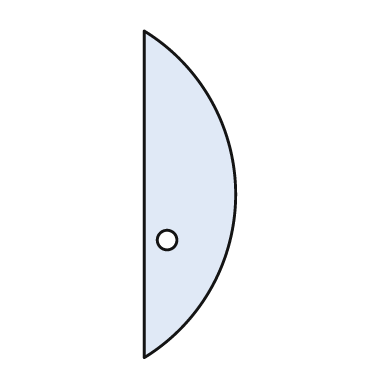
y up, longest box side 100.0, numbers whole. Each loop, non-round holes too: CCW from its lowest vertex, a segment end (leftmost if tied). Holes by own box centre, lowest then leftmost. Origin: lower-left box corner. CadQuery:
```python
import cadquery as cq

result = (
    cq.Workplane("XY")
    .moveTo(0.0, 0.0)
    .threePointArc((28.0, 50.0), (0.0, 100.0))
    .close()
    .moveTo(7.0, 36.0)
    .circle(3.0)
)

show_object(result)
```